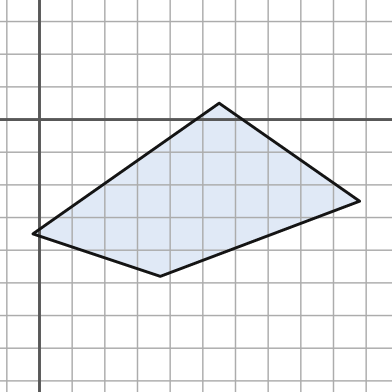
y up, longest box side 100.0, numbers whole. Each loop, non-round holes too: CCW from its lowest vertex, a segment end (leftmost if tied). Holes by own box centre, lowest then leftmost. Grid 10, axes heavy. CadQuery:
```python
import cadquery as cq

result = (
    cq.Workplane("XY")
    .moveTo(37.0, -48.0)
    .lineTo(98.0, -25.0)
    .lineTo(55.0, 5.0)
    .lineTo(-2.0, -35.0)
    .close()
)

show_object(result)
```